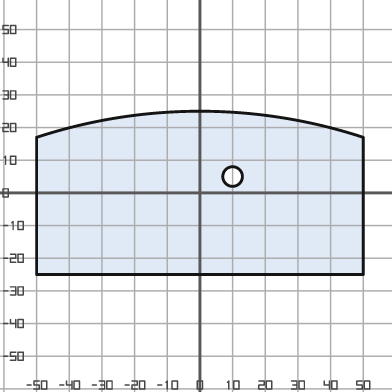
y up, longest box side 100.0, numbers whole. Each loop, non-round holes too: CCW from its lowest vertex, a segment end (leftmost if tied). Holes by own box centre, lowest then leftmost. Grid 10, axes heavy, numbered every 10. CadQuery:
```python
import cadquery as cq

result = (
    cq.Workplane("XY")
    .moveTo(-50.0, -25.0)
    .lineTo(50.0, -25.0)
    .lineTo(50.0, 17.0)
    .threePointArc((0.0, 25.0), (-50.0, 17.0))
    .close()
    .moveTo(10.0, 5.0)
    .circle(3.0)
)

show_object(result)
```